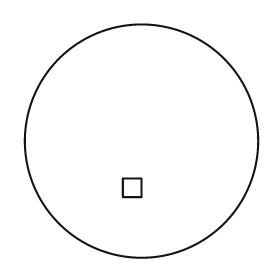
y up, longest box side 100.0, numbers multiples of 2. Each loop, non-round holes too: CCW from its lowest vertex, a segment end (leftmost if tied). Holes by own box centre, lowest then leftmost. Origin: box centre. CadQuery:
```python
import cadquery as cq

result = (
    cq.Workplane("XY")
    .moveTo(0.0, 0.0)
    .circle(50.0)
    .moveTo(-8.0, -24.0)
    .lineTo(0.0, -24.0)
    .lineTo(0.0, -16.0)
    .lineTo(-8.0, -16.0)
    .close()
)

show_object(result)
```